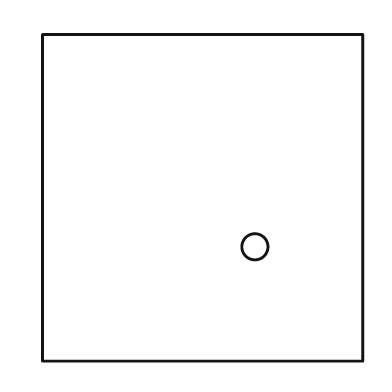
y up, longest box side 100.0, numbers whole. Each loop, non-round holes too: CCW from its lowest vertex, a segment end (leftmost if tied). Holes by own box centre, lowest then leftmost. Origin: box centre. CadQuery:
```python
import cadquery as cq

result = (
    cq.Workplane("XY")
    .moveTo(-49.0, -50.0)
    .lineTo(49.0, -50.0)
    .lineTo(49.0, 50.0)
    .lineTo(-49.0, 50.0)
    .close()
    .moveTo(16.0, -15.0)
    .circle(4.0)
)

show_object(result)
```